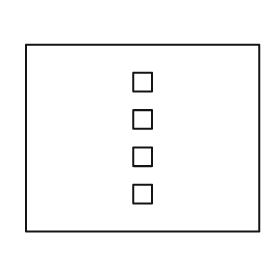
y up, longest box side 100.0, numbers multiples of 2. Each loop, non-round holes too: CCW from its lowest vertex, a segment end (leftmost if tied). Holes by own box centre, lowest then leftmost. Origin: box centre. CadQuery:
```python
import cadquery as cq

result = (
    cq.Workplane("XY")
    .moveTo(-50.0, -40.0)
    .lineTo(50.0, -40.0)
    .lineTo(50.0, 40.0)
    .lineTo(-50.0, 40.0)
    .close()
    .moveTo(-4.0, -28.0)
    .lineTo(4.0, -28.0)
    .lineTo(4.0, -20.0)
    .lineTo(-4.0, -20.0)
    .close()
    .moveTo(-4.0, -12.0)
    .lineTo(4.0, -12.0)
    .lineTo(4.0, -4.0)
    .lineTo(-4.0, -4.0)
    .close()
    .moveTo(-4.0, 4.0)
    .lineTo(4.0, 4.0)
    .lineTo(4.0, 12.0)
    .lineTo(-4.0, 12.0)
    .close()
    .moveTo(-4.0, 20.0)
    .lineTo(4.0, 20.0)
    .lineTo(4.0, 28.0)
    .lineTo(-4.0, 28.0)
    .close()
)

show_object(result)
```